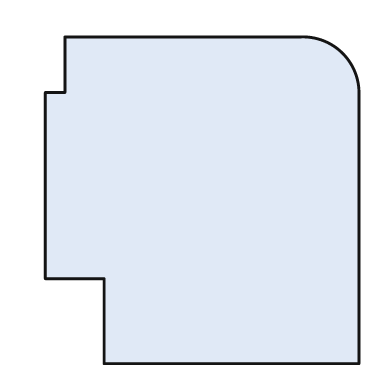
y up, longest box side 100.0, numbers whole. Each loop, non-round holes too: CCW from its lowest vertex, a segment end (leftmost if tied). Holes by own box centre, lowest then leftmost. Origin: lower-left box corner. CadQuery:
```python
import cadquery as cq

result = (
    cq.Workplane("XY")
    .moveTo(18.0, 0.0)
    .lineTo(96.0, 0.0)
    .lineTo(96.0, 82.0)
    .threePointArc((91.0, 95.0), (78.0, 100.0))
    .lineTo(6.0, 100.0)
    .lineTo(6.0, 83.0)
    .lineTo(0.0, 83.0)
    .lineTo(0.0, 26.0)
    .lineTo(18.0, 26.0)
    .close()
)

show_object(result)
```